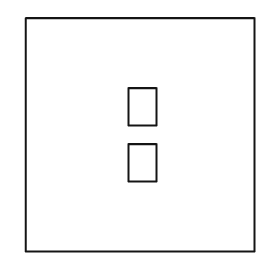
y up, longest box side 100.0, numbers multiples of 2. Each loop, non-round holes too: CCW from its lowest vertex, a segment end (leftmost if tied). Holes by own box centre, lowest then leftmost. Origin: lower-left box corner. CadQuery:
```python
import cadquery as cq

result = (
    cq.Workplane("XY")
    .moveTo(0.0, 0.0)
    .lineTo(98.0, 0.0)
    .lineTo(98.0, 100.0)
    .lineTo(0.0, 100.0)
    .close()
    .moveTo(44.0, 30.0)
    .lineTo(56.0, 30.0)
    .lineTo(56.0, 46.0)
    .lineTo(44.0, 46.0)
    .close()
    .moveTo(44.0, 54.0)
    .lineTo(56.0, 54.0)
    .lineTo(56.0, 70.0)
    .lineTo(44.0, 70.0)
    .close()
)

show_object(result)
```